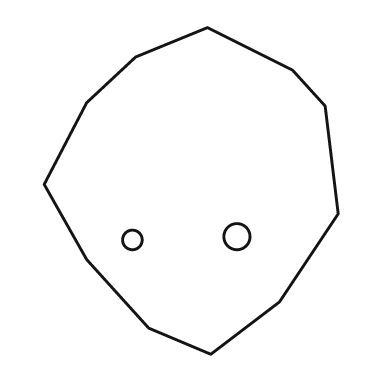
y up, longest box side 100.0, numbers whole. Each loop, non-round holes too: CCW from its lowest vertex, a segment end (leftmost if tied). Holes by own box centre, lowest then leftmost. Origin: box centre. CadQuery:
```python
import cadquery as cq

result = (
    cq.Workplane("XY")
    .moveTo(6.0, -50.0)
    .lineTo(27.0, -34.0)
    .lineTo(45.0, -7.0)
    .lineTo(41.0, 26.0)
    .lineTo(31.0, 37.0)
    .lineTo(5.0, 50.0)
    .lineTo(-17.0, 41.0)
    .lineTo(-32.0, 27.0)
    .lineTo(-45.0, 2.0)
    .lineTo(-32.0, -21.0)
    .lineTo(-13.0, -42.0)
    .close()
    .moveTo(-18.0, -15.0)
    .circle(3.0)
    .moveTo(14.0, -14.0)
    .circle(4.0)
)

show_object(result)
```